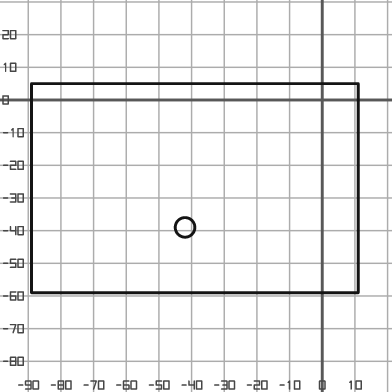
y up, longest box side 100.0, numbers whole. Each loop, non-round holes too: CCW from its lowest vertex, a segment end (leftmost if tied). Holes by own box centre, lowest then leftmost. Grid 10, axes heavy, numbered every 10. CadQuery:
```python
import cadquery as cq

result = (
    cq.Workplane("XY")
    .moveTo(-89.0, -59.0)
    .lineTo(11.0, -59.0)
    .lineTo(11.0, 5.0)
    .lineTo(-89.0, 5.0)
    .close()
    .moveTo(-42.0, -39.0)
    .circle(3.0)
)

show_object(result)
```